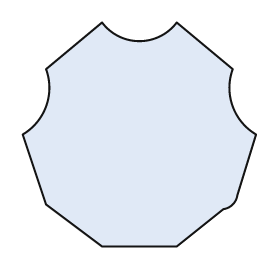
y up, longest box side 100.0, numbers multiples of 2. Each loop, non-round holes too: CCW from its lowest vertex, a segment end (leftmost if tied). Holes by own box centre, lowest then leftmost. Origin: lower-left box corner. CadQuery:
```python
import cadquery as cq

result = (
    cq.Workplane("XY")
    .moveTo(34.0, 0.0)
    .lineTo(66.0, 0.0)
    .lineTo(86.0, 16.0)
    .threePointArc((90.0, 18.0), (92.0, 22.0))
    .lineTo(100.0, 48.0)
    .threePointArc((90.0, 60.0), (90.0, 76.0))
    .lineTo(66.0, 96.0)
    .threePointArc((50.0, 88.0), (34.0, 96.0))
    .lineTo(10.0, 76.0)
    .threePointArc((10.0, 60.0), (0.0, 48.0))
    .lineTo(10.0, 18.0)
    .close()
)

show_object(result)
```